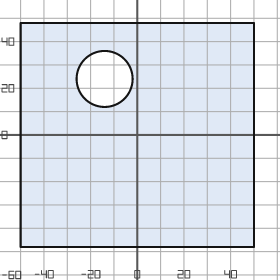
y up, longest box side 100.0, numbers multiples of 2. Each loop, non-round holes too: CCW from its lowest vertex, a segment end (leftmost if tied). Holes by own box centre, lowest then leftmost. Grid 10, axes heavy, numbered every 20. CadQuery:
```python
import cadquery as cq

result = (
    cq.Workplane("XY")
    .moveTo(-50.0, -48.0)
    .lineTo(50.0, -48.0)
    .lineTo(50.0, 48.0)
    .lineTo(-50.0, 48.0)
    .close()
    .moveTo(-14.0, 24.0)
    .circle(12.0)
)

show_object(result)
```